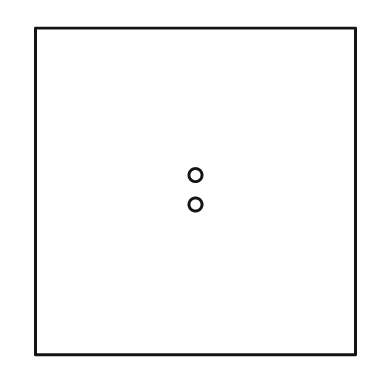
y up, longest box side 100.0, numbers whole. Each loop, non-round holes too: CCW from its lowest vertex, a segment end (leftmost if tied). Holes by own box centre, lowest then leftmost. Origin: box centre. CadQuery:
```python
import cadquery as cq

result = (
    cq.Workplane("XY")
    .moveTo(-49.0, -50.0)
    .lineTo(49.0, -50.0)
    .lineTo(49.0, 50.0)
    .lineTo(-49.0, 50.0)
    .close()
    .moveTo(0.0, -4.0)
    .circle(2.0)
    .moveTo(0.0, 5.0)
    .circle(2.0)
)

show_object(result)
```